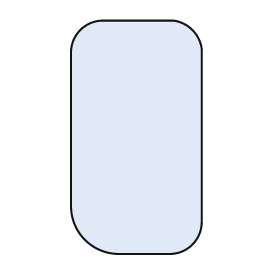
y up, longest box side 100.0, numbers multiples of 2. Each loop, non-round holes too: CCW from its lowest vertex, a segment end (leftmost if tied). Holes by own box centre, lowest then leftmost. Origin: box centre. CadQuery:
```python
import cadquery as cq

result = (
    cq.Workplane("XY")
    .moveTo(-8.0, -50.0)
    .lineTo(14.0, -50.0)
    .threePointArc((24.0, -46.0), (28.0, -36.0))
    .lineTo(28.0, 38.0)
    .threePointArc((24.0, 46.0), (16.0, 50.0))
    .lineTo(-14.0, 50.0)
    .threePointArc((-24.0, 46.0), (-28.0, 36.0))
    .lineTo(-28.0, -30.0)
    .threePointArc((-22.0, -44.0), (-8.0, -50.0))
    .close()
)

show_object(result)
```